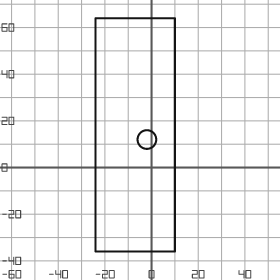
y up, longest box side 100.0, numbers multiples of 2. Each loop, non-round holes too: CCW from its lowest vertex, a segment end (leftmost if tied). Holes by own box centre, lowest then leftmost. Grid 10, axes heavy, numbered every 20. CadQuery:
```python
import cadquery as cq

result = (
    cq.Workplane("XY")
    .moveTo(-24.0, -36.0)
    .lineTo(10.0, -36.0)
    .lineTo(10.0, 64.0)
    .lineTo(-24.0, 64.0)
    .close()
    .moveTo(-2.0, 12.0)
    .circle(4.0)
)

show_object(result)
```